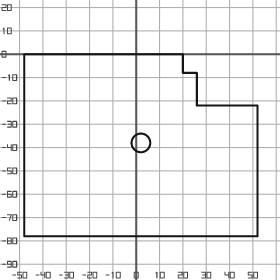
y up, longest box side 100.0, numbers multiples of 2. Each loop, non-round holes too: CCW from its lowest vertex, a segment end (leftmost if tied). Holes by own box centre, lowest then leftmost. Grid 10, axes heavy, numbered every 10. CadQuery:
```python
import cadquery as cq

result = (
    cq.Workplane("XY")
    .moveTo(-48.0, -78.0)
    .lineTo(52.0, -78.0)
    .lineTo(52.0, -22.0)
    .lineTo(26.0, -22.0)
    .lineTo(26.0, -8.0)
    .lineTo(20.0, -8.0)
    .lineTo(20.0, 0.0)
    .lineTo(-48.0, 0.0)
    .close()
    .moveTo(2.0, -38.0)
    .circle(4.0)
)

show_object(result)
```